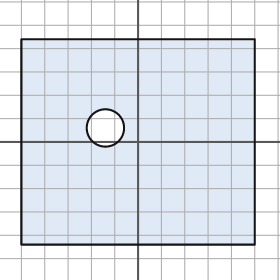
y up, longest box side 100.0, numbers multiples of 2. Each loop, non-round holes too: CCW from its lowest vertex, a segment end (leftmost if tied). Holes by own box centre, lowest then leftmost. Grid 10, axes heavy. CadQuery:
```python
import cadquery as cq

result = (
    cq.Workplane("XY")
    .moveTo(-50.0, -44.0)
    .lineTo(50.0, -44.0)
    .lineTo(50.0, 44.0)
    .lineTo(-50.0, 44.0)
    .close()
    .moveTo(-14.0, 6.0)
    .circle(8.0)
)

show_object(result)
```